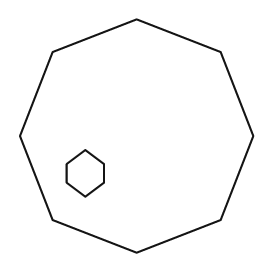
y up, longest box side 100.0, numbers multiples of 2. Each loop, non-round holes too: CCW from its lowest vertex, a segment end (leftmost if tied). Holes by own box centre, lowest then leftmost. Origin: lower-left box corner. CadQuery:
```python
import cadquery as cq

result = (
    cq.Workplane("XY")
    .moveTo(50.0, 0.0)
    .lineTo(86.0, 14.0)
    .lineTo(100.0, 50.0)
    .lineTo(86.0, 86.0)
    .lineTo(50.0, 100.0)
    .lineTo(14.0, 86.0)
    .lineTo(0.0, 50.0)
    .lineTo(14.0, 14.0)
    .close()
    .moveTo(28.0, 24.0)
    .lineTo(36.0, 30.0)
    .lineTo(36.0, 38.0)
    .lineTo(28.0, 44.0)
    .lineTo(20.0, 38.0)
    .lineTo(20.0, 30.0)
    .close()
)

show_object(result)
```